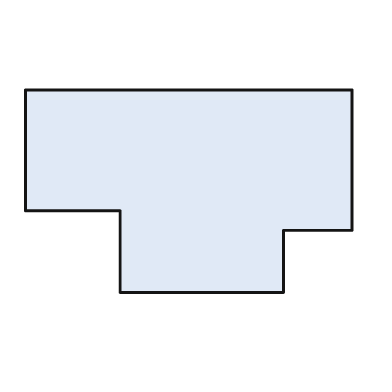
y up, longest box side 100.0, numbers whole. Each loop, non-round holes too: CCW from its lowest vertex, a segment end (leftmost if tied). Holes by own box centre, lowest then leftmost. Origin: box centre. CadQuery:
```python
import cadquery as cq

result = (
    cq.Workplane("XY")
    .moveTo(-21.0, -31.0)
    .lineTo(29.0, -31.0)
    .lineTo(29.0, -12.0)
    .lineTo(50.0, -12.0)
    .lineTo(50.0, 31.0)
    .lineTo(-50.0, 31.0)
    .lineTo(-50.0, -6.0)
    .lineTo(-21.0, -6.0)
    .close()
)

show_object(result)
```